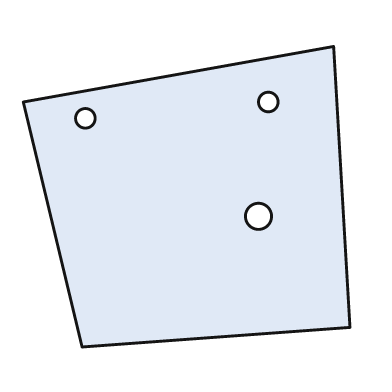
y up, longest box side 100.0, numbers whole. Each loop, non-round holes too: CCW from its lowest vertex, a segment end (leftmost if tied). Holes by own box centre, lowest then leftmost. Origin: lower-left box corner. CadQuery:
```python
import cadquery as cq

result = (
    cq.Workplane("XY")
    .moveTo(18.0, 0.0)
    .lineTo(100.0, 6.0)
    .lineTo(95.0, 92.0)
    .lineTo(0.0, 75.0)
    .close()
    .moveTo(72.0, 40.0)
    .circle(4.0)
    .moveTo(19.0, 70.0)
    .circle(3.0)
    .moveTo(75.0, 75.0)
    .circle(3.0)
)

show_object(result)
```